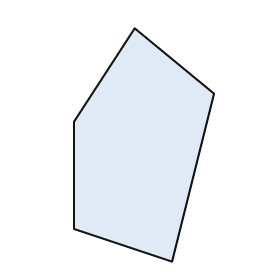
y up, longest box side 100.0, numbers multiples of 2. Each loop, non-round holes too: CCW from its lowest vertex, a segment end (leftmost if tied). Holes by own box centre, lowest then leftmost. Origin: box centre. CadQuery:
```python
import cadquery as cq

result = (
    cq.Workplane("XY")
    .moveTo(12.0, -50.0)
    .lineTo(30.0, 22.0)
    .lineTo(-4.0, 50.0)
    .lineTo(-30.0, 10.0)
    .lineTo(-30.0, -36.0)
    .close()
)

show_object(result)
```